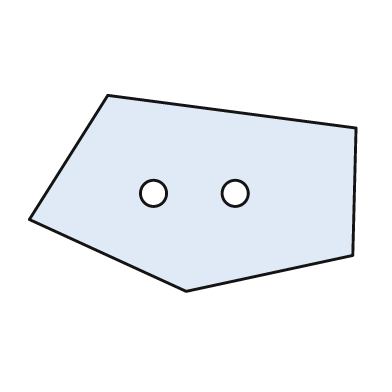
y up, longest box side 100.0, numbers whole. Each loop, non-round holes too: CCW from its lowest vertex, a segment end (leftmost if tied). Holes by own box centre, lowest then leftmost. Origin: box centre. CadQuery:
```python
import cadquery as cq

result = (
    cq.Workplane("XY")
    .moveTo(-2.0, -30.0)
    .lineTo(49.0, -19.0)
    .lineTo(50.0, 20.0)
    .lineTo(-26.0, 30.0)
    .lineTo(-50.0, -8.0)
    .close()
    .moveTo(-12.0, 0.0)
    .circle(4.0)
    .moveTo(13.0, 0.0)
    .circle(4.0)
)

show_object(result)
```